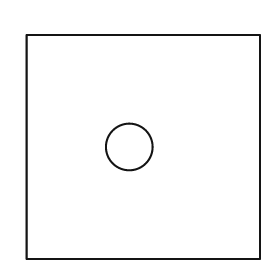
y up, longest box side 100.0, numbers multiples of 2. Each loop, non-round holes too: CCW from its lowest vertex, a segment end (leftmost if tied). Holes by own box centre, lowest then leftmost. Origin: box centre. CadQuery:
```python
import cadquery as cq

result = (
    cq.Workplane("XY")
    .moveTo(-50.0, -48.0)
    .lineTo(50.0, -48.0)
    .lineTo(50.0, 48.0)
    .lineTo(-50.0, 48.0)
    .close()
    .moveTo(-6.0, 0.0)
    .circle(10.0)
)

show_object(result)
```